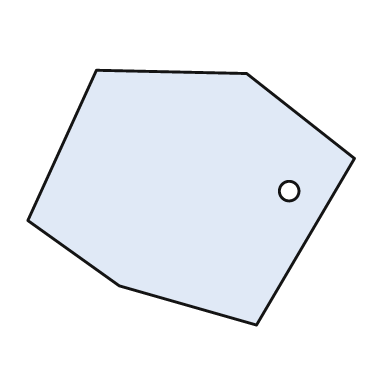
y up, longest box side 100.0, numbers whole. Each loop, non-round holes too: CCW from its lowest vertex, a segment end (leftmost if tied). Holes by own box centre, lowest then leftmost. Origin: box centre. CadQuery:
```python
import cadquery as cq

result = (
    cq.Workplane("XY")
    .moveTo(20.0, -39.0)
    .lineTo(50.0, 12.0)
    .lineTo(17.0, 38.0)
    .lineTo(-29.0, 39.0)
    .lineTo(-50.0, -7.0)
    .lineTo(-22.0, -27.0)
    .close()
    .moveTo(30.0, 2.0)
    .circle(3.0)
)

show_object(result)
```